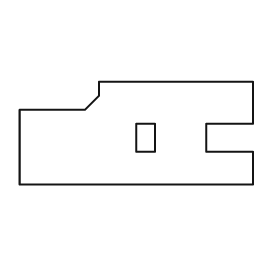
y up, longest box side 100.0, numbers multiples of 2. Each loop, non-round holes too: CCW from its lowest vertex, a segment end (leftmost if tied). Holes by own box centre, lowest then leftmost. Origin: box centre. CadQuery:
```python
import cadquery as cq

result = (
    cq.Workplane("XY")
    .moveTo(-50.0, -22.0)
    .lineTo(50.0, -22.0)
    .lineTo(50.0, -8.0)
    .lineTo(30.0, -8.0)
    .lineTo(30.0, 4.0)
    .lineTo(50.0, 4.0)
    .lineTo(50.0, 22.0)
    .lineTo(-16.0, 22.0)
    .lineTo(-16.0, 16.0)
    .lineTo(-22.0, 10.0)
    .lineTo(-50.0, 10.0)
    .close()
    .moveTo(0.0, -8.0)
    .lineTo(8.0, -8.0)
    .lineTo(8.0, 4.0)
    .lineTo(0.0, 4.0)
    .close()
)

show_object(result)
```